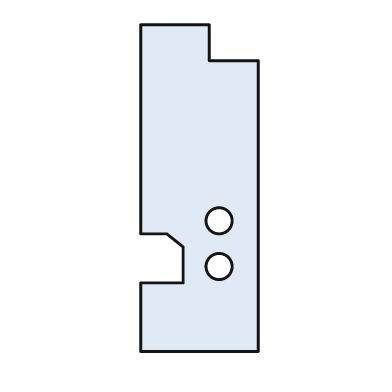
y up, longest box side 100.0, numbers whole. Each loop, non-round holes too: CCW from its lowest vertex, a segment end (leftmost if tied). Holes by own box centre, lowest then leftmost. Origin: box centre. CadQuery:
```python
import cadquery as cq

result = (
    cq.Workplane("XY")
    .moveTo(-18.0, -50.0)
    .lineTo(18.0, -50.0)
    .lineTo(18.0, 39.0)
    .lineTo(3.0, 39.0)
    .lineTo(3.0, 50.0)
    .lineTo(-18.0, 50.0)
    .lineTo(-18.0, -14.0)
    .lineTo(-10.0, -14.0)
    .lineTo(-5.0, -18.0)
    .lineTo(-5.0, -29.0)
    .lineTo(-18.0, -29.0)
    .close()
    .moveTo(6.0, -24.0)
    .circle(4.0)
    .moveTo(6.0, -10.0)
    .circle(4.0)
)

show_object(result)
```